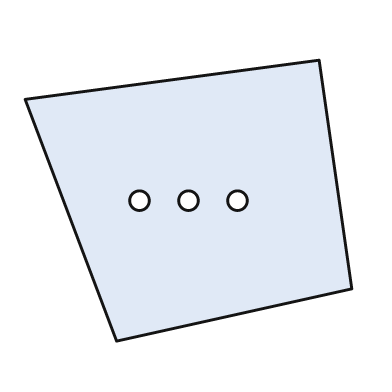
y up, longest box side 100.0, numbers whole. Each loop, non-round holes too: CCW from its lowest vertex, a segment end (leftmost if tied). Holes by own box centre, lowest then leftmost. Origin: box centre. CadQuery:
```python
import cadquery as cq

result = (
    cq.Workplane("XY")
    .moveTo(-22.0, -43.0)
    .lineTo(50.0, -27.0)
    .lineTo(40.0, 43.0)
    .lineTo(-50.0, 31.0)
    .close()
    .moveTo(-15.0, 0.0)
    .circle(3.0)
    .moveTo(0.0, 0.0)
    .circle(3.0)
    .moveTo(15.0, 0.0)
    .circle(3.0)
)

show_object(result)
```